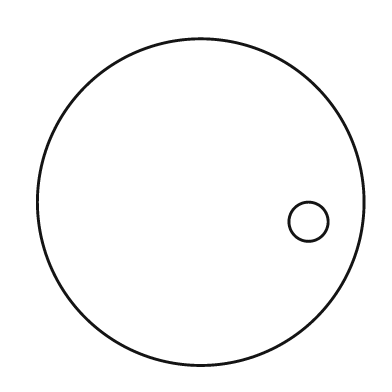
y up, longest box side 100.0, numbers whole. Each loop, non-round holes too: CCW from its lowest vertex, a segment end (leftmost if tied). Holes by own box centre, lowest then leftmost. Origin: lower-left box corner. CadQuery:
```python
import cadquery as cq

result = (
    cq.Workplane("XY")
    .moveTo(50.0, 50.0)
    .circle(50.0)
    .moveTo(83.0, 44.0)
    .circle(6.0)
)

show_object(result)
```